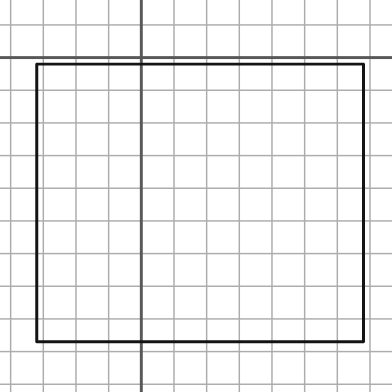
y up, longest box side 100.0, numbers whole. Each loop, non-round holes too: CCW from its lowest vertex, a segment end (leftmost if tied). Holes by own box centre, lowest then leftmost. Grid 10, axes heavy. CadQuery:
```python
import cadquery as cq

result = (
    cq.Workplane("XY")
    .moveTo(-32.0, -87.0)
    .lineTo(68.0, -87.0)
    .lineTo(68.0, -2.0)
    .lineTo(-32.0, -2.0)
    .close()
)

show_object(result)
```